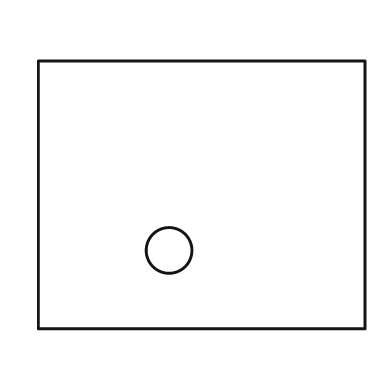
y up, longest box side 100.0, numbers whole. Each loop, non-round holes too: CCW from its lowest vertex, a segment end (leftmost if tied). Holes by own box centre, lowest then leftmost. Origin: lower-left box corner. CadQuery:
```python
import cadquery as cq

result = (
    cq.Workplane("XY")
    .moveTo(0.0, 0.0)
    .lineTo(100.0, 0.0)
    .lineTo(100.0, 82.0)
    .lineTo(0.0, 82.0)
    .close()
    .moveTo(40.0, 24.0)
    .circle(7.0)
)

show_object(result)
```